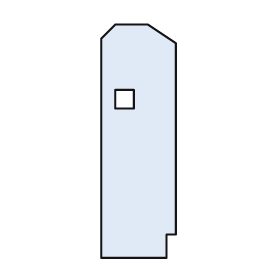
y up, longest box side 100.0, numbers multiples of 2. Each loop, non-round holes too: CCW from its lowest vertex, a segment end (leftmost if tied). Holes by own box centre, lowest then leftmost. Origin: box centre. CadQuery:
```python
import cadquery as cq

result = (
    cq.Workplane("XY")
    .moveTo(-16.0, -50.0)
    .lineTo(12.0, -50.0)
    .lineTo(12.0, -40.0)
    .lineTo(16.0, -40.0)
    .lineTo(16.0, 42.0)
    .lineTo(4.0, 50.0)
    .lineTo(-10.0, 50.0)
    .lineTo(-16.0, 44.0)
    .close()
    .moveTo(-10.0, 14.0)
    .lineTo(-2.0, 14.0)
    .lineTo(-2.0, 22.0)
    .lineTo(-10.0, 22.0)
    .close()
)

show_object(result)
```